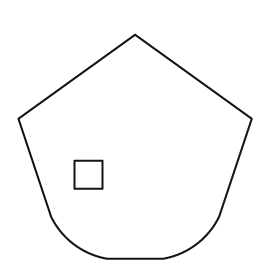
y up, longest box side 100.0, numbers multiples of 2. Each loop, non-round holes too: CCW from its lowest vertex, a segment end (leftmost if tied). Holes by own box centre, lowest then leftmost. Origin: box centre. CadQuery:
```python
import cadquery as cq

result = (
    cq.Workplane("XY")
    .moveTo(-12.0, -48.0)
    .lineTo(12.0, -48.0)
    .threePointArc((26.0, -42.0), (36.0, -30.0))
    .lineTo(50.0, 12.0)
    .lineTo(0.0, 48.0)
    .lineTo(-50.0, 12.0)
    .lineTo(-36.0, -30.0)
    .threePointArc((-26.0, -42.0), (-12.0, -48.0))
    .close()
    .moveTo(-26.0, -18.0)
    .lineTo(-14.0, -18.0)
    .lineTo(-14.0, -6.0)
    .lineTo(-26.0, -6.0)
    .close()
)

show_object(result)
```